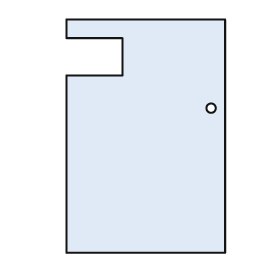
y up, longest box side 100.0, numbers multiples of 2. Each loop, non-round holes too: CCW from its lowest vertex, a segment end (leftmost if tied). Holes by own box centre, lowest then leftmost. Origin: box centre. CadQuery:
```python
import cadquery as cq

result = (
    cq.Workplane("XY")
    .moveTo(-34.0, -50.0)
    .lineTo(34.0, -50.0)
    .lineTo(34.0, 50.0)
    .lineTo(-34.0, 50.0)
    .lineTo(-34.0, 42.0)
    .lineTo(-10.0, 42.0)
    .lineTo(-10.0, 26.0)
    .lineTo(-34.0, 26.0)
    .close()
    .moveTo(28.0, 12.0)
    .circle(2.0)
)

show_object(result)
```